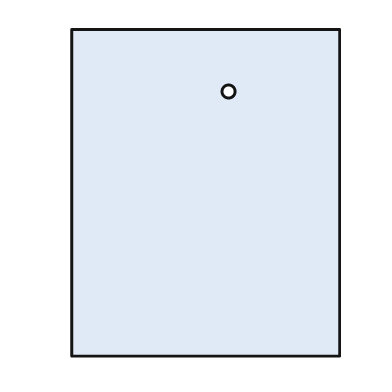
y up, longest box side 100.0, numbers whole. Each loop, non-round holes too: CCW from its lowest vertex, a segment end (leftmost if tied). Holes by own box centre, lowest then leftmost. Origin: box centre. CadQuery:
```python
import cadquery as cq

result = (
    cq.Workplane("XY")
    .moveTo(-41.0, -50.0)
    .lineTo(41.0, -50.0)
    .lineTo(41.0, 50.0)
    .lineTo(-41.0, 50.0)
    .close()
    .moveTo(7.0, 31.0)
    .circle(2.0)
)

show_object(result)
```